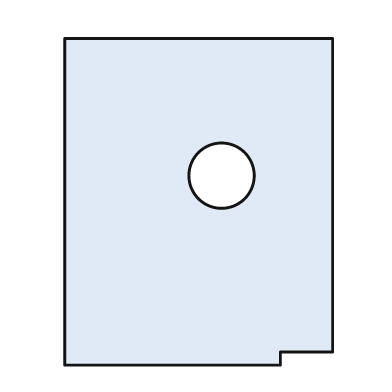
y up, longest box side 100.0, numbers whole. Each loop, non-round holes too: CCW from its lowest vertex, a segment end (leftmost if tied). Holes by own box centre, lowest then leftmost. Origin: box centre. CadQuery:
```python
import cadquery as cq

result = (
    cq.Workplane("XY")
    .moveTo(-41.0, -50.0)
    .lineTo(25.0, -50.0)
    .lineTo(25.0, -46.0)
    .lineTo(41.0, -46.0)
    .lineTo(41.0, 50.0)
    .lineTo(-41.0, 50.0)
    .close()
    .moveTo(7.0, 8.0)
    .circle(10.0)
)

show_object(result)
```